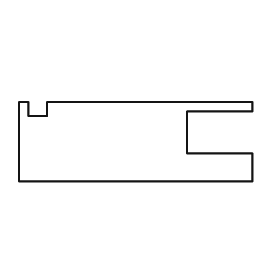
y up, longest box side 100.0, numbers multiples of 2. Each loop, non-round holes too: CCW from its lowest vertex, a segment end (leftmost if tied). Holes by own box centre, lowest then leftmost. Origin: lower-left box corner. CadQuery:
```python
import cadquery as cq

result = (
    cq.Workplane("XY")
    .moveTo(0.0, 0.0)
    .lineTo(100.0, 0.0)
    .lineTo(100.0, 12.0)
    .lineTo(72.0, 12.0)
    .lineTo(72.0, 30.0)
    .lineTo(100.0, 30.0)
    .lineTo(100.0, 34.0)
    .lineTo(12.0, 34.0)
    .lineTo(12.0, 28.0)
    .lineTo(4.0, 28.0)
    .lineTo(4.0, 34.0)
    .lineTo(0.0, 34.0)
    .close()
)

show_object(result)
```